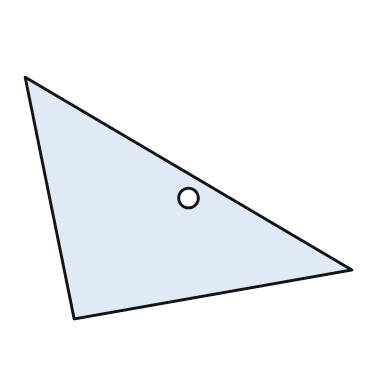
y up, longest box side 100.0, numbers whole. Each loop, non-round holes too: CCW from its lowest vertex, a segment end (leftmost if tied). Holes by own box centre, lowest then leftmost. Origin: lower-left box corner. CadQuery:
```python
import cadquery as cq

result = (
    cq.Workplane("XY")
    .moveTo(15.0, 0.0)
    .lineTo(100.0, 15.0)
    .lineTo(0.0, 74.0)
    .close()
    .moveTo(50.0, 37.0)
    .circle(3.0)
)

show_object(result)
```